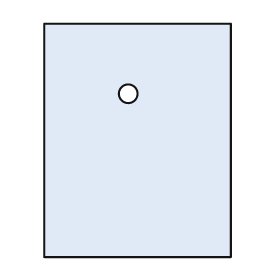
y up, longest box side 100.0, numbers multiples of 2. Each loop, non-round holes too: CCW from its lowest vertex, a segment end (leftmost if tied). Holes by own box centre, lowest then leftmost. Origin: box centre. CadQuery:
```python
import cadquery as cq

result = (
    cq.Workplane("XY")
    .moveTo(-40.0, -50.0)
    .lineTo(40.0, -50.0)
    .lineTo(40.0, 50.0)
    .lineTo(-40.0, 50.0)
    .close()
    .moveTo(-4.0, 20.0)
    .circle(4.0)
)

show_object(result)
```